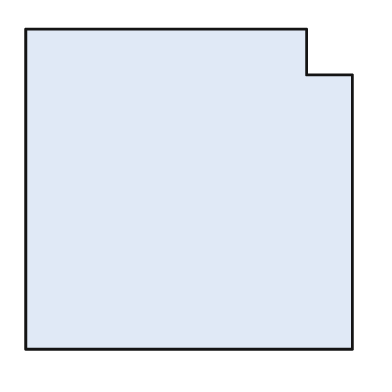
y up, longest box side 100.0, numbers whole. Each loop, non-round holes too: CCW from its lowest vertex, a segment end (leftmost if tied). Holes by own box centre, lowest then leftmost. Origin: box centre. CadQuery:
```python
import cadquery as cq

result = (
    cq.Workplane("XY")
    .moveTo(-50.0, -49.0)
    .lineTo(50.0, -49.0)
    .lineTo(50.0, 35.0)
    .lineTo(36.0, 35.0)
    .lineTo(36.0, 49.0)
    .lineTo(-50.0, 49.0)
    .close()
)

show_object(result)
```